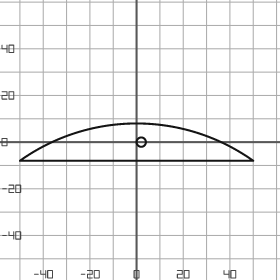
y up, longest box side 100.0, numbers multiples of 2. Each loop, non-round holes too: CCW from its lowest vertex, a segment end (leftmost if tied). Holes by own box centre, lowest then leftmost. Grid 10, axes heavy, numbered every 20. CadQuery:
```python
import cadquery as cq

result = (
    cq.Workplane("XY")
    .moveTo(-50.0, -8.0)
    .lineTo(50.0, -8.0)
    .threePointArc((0.0, 8.0), (-50.0, -8.0))
    .close()
    .moveTo(2.0, 0.0)
    .circle(2.0)
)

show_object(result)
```